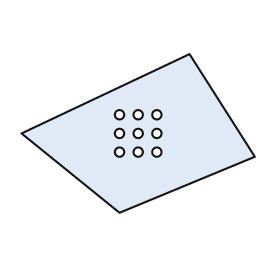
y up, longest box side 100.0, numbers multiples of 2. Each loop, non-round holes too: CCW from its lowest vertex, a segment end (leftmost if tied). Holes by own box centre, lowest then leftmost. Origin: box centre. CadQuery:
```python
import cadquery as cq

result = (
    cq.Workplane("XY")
    .moveTo(-8.0, -34.0)
    .lineTo(50.0, -10.0)
    .lineTo(22.0, 34.0)
    .lineTo(-50.0, 0.0)
    .close()
    .moveTo(-8.0, -8.0)
    .circle(2.0)
    .moveTo(0.0, -8.0)
    .circle(2.0)
    .moveTo(8.0, -8.0)
    .circle(2.0)
    .moveTo(-8.0, 0.0)
    .circle(2.0)
    .moveTo(0.0, 0.0)
    .circle(2.0)
    .moveTo(8.0, 0.0)
    .circle(2.0)
    .moveTo(-8.0, 8.0)
    .circle(2.0)
    .moveTo(0.0, 8.0)
    .circle(2.0)
    .moveTo(8.0, 8.0)
    .circle(2.0)
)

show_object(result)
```